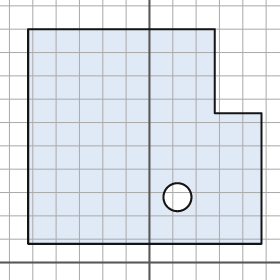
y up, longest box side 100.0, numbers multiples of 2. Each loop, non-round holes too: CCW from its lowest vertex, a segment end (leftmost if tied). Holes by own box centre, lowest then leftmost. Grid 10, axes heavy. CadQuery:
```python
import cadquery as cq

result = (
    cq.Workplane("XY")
    .moveTo(-52.0, 8.0)
    .lineTo(48.0, 8.0)
    .lineTo(48.0, 64.0)
    .lineTo(28.0, 64.0)
    .lineTo(28.0, 100.0)
    .lineTo(-52.0, 100.0)
    .close()
    .moveTo(12.0, 28.0)
    .circle(6.0)
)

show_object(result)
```